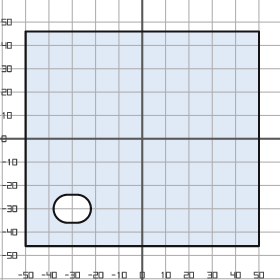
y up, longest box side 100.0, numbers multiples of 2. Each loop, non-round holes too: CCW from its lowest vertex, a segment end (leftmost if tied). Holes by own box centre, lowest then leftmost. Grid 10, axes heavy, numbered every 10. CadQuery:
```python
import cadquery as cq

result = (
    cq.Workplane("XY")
    .moveTo(-50.0, -46.0)
    .lineTo(50.0, -46.0)
    .lineTo(50.0, 46.0)
    .lineTo(-50.0, 46.0)
    .close()
    .moveTo(-32.0, -36.0)
    .lineTo(-28.0, -36.0)
    .threePointArc((-22.0, -30.0), (-28.0, -24.0))
    .lineTo(-32.0, -24.0)
    .threePointArc((-38.0, -30.0), (-32.0, -36.0))
    .close()
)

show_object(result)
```